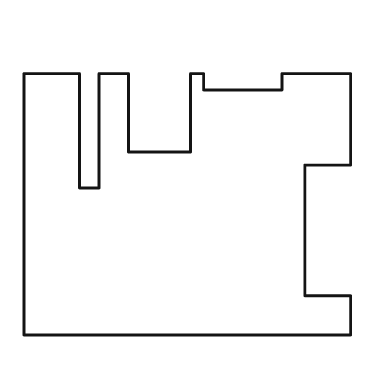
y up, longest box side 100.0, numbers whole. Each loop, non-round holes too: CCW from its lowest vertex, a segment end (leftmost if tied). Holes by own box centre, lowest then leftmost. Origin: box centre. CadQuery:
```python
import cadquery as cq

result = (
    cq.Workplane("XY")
    .moveTo(-50.0, -40.0)
    .lineTo(50.0, -40.0)
    .lineTo(50.0, -28.0)
    .lineTo(36.0, -28.0)
    .lineTo(36.0, 12.0)
    .lineTo(50.0, 12.0)
    .lineTo(50.0, 40.0)
    .lineTo(29.0, 40.0)
    .lineTo(29.0, 35.0)
    .lineTo(5.0, 35.0)
    .lineTo(5.0, 40.0)
    .lineTo(1.0, 40.0)
    .lineTo(1.0, 16.0)
    .lineTo(-18.0, 16.0)
    .lineTo(-18.0, 40.0)
    .lineTo(-27.0, 40.0)
    .lineTo(-27.0, 5.0)
    .lineTo(-33.0, 5.0)
    .lineTo(-33.0, 40.0)
    .lineTo(-50.0, 40.0)
    .close()
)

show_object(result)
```